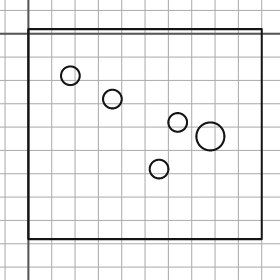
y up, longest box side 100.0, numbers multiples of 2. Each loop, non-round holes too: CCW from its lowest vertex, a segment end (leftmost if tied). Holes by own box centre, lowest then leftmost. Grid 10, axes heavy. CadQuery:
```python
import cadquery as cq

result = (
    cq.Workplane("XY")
    .moveTo(0.0, -88.0)
    .lineTo(100.0, -88.0)
    .lineTo(100.0, 2.0)
    .lineTo(0.0, 2.0)
    .close()
    .moveTo(56.0, -58.0)
    .circle(4.0)
    .moveTo(78.0, -44.0)
    .circle(6.0)
    .moveTo(64.0, -38.0)
    .circle(4.0)
    .moveTo(36.0, -28.0)
    .circle(4.0)
    .moveTo(18.0, -18.0)
    .circle(4.0)
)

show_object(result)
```